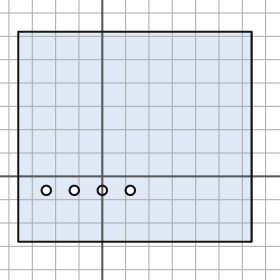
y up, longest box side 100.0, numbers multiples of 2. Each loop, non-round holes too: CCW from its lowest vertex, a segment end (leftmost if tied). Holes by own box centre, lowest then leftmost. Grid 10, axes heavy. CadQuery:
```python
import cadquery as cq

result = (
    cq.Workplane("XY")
    .moveTo(-36.0, -28.0)
    .lineTo(64.0, -28.0)
    .lineTo(64.0, 62.0)
    .lineTo(-36.0, 62.0)
    .close()
    .moveTo(-24.0, -6.0)
    .circle(2.0)
    .moveTo(-12.0, -6.0)
    .circle(2.0)
    .moveTo(0.0, -6.0)
    .circle(2.0)
    .moveTo(12.0, -6.0)
    .circle(2.0)
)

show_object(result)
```